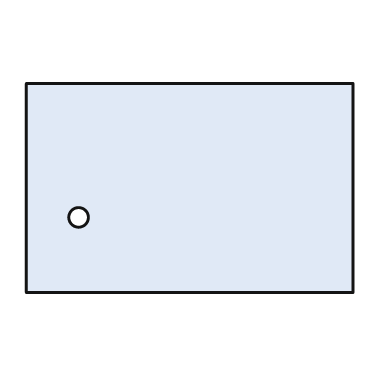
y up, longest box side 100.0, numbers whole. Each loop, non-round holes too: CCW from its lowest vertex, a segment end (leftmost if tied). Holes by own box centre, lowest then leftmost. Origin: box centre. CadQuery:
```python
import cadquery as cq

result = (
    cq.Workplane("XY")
    .moveTo(-50.0, -32.0)
    .lineTo(50.0, -32.0)
    .lineTo(50.0, 32.0)
    .lineTo(-50.0, 32.0)
    .close()
    .moveTo(-34.0, -9.0)
    .circle(3.0)
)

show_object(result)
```